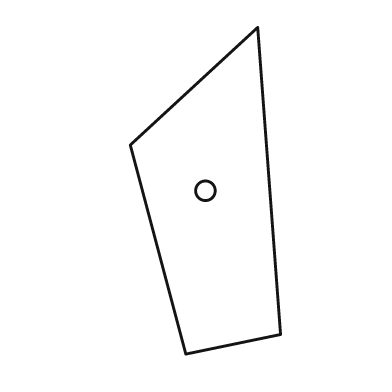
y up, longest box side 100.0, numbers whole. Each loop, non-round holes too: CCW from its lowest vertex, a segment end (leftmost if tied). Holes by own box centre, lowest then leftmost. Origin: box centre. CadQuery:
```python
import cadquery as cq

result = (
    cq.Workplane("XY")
    .moveTo(-6.0, -50.0)
    .lineTo(23.0, -44.0)
    .lineTo(16.0, 50.0)
    .lineTo(-23.0, 14.0)
    .close()
    .moveTo(0.0, 0.0)
    .circle(3.0)
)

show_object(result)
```